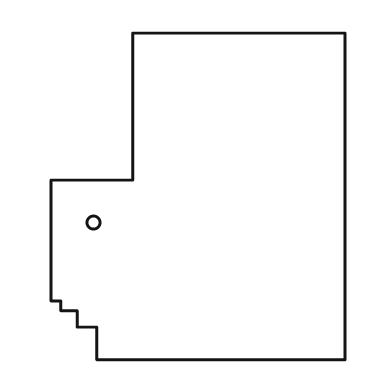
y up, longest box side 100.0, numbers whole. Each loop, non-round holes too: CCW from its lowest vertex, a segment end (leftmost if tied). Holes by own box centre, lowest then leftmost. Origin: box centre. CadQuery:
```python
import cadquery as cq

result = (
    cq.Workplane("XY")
    .moveTo(-31.0, -50.0)
    .lineTo(45.0, -50.0)
    .lineTo(45.0, 50.0)
    .lineTo(-20.0, 50.0)
    .lineTo(-20.0, 5.0)
    .lineTo(-45.0, 5.0)
    .lineTo(-45.0, -32.0)
    .lineTo(-42.0, -32.0)
    .lineTo(-42.0, -35.0)
    .lineTo(-37.0, -35.0)
    .lineTo(-37.0, -40.0)
    .lineTo(-31.0, -40.0)
    .close()
    .moveTo(-32.0, -8.0)
    .circle(2.0)
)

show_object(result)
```